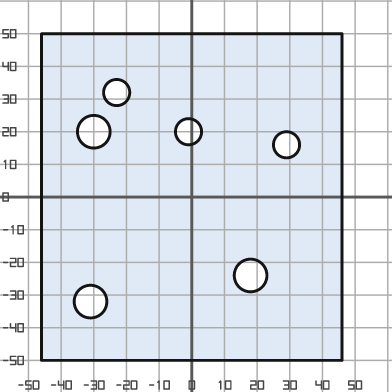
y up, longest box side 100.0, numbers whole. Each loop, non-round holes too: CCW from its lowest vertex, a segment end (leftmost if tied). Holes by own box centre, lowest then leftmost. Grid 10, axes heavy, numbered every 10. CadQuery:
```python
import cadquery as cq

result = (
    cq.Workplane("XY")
    .moveTo(-46.0, -50.0)
    .lineTo(46.0, -50.0)
    .lineTo(46.0, 50.0)
    .lineTo(-46.0, 50.0)
    .close()
    .moveTo(-31.0, -32.0)
    .circle(5.0)
    .moveTo(18.0, -24.0)
    .circle(5.0)
    .moveTo(29.0, 16.0)
    .circle(4.0)
    .moveTo(-30.0, 20.0)
    .circle(5.0)
    .moveTo(-1.0, 20.0)
    .circle(4.0)
    .moveTo(-23.0, 32.0)
    .circle(4.0)
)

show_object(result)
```